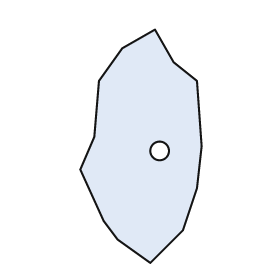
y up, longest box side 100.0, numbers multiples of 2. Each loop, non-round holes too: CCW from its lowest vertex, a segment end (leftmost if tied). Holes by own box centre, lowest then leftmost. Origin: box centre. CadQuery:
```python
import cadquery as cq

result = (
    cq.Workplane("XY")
    .moveTo(4.0, -50.0)
    .lineTo(18.0, -36.0)
    .lineTo(24.0, -18.0)
    .lineTo(26.0, 0.0)
    .lineTo(24.0, 28.0)
    .lineTo(14.0, 36.0)
    .lineTo(6.0, 50.0)
    .lineTo(-8.0, 42.0)
    .lineTo(-18.0, 28.0)
    .lineTo(-20.0, 4.0)
    .lineTo(-26.0, -10.0)
    .lineTo(-16.0, -32.0)
    .lineTo(-10.0, -40.0)
    .close()
    .moveTo(8.0, -2.0)
    .circle(4.0)
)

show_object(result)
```